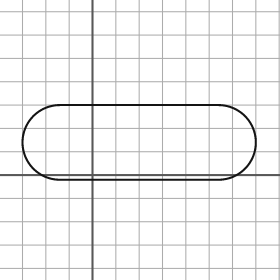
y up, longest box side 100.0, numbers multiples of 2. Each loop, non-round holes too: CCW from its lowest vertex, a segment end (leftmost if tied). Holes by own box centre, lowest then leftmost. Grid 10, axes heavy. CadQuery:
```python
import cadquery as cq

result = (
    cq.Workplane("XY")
    .moveTo(-14.0, -2.0)
    .lineTo(54.0, -2.0)
    .threePointArc((70.0, 14.0), (54.0, 30.0))
    .lineTo(-14.0, 30.0)
    .threePointArc((-30.0, 14.0), (-14.0, -2.0))
    .close()
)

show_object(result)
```